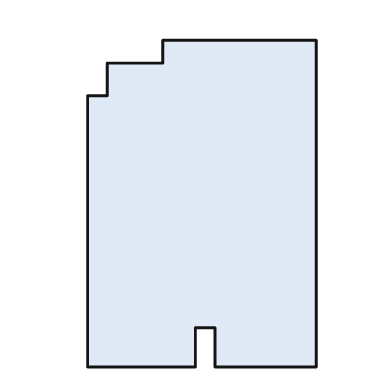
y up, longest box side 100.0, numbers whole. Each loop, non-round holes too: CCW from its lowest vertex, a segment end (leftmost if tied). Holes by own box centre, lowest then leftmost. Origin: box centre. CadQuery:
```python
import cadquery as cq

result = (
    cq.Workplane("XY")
    .moveTo(-35.0, -50.0)
    .lineTo(-2.0, -50.0)
    .lineTo(-2.0, -38.0)
    .lineTo(4.0, -38.0)
    .lineTo(4.0, -50.0)
    .lineTo(35.0, -50.0)
    .lineTo(35.0, 50.0)
    .lineTo(-12.0, 50.0)
    .lineTo(-12.0, 43.0)
    .lineTo(-29.0, 43.0)
    .lineTo(-29.0, 33.0)
    .lineTo(-35.0, 33.0)
    .close()
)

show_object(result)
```